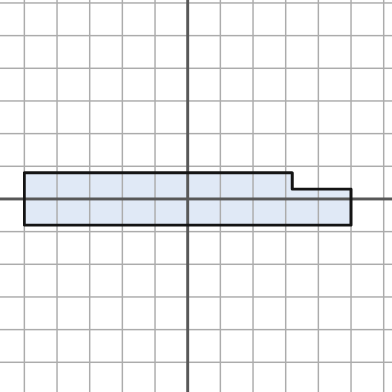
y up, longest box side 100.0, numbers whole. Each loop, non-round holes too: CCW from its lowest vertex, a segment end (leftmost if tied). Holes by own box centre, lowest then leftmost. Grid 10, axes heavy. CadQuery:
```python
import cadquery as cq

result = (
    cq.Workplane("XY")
    .moveTo(-50.0, -8.0)
    .lineTo(50.0, -8.0)
    .lineTo(50.0, 3.0)
    .lineTo(32.0, 3.0)
    .lineTo(32.0, 8.0)
    .lineTo(-50.0, 8.0)
    .close()
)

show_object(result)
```